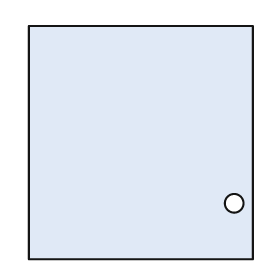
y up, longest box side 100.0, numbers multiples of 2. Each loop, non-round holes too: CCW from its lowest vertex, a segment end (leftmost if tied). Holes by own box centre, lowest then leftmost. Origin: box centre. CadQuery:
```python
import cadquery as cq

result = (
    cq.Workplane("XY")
    .moveTo(-48.0, -50.0)
    .lineTo(48.0, -50.0)
    .lineTo(48.0, 50.0)
    .lineTo(-48.0, 50.0)
    .close()
    .moveTo(40.0, -26.0)
    .circle(4.0)
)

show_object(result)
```